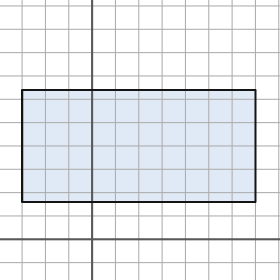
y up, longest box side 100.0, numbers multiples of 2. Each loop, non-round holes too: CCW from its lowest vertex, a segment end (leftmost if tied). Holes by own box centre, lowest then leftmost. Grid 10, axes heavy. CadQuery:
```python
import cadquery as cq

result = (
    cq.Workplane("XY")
    .moveTo(-30.0, 16.0)
    .lineTo(70.0, 16.0)
    .lineTo(70.0, 64.0)
    .lineTo(-30.0, 64.0)
    .close()
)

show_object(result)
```